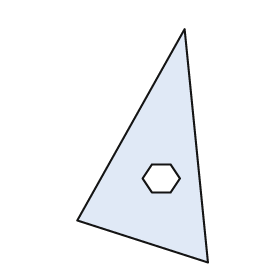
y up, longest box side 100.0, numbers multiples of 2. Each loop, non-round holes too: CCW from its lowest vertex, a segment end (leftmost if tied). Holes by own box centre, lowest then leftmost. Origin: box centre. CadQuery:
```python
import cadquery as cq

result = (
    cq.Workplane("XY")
    .moveTo(28.0, -50.0)
    .lineTo(18.0, 50.0)
    .lineTo(-28.0, -32.0)
    .close()
    .moveTo(4.0, -20.0)
    .lineTo(12.0, -20.0)
    .lineTo(16.0, -14.0)
    .lineTo(12.0, -8.0)
    .lineTo(4.0, -8.0)
    .lineTo(0.0, -14.0)
    .close()
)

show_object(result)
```